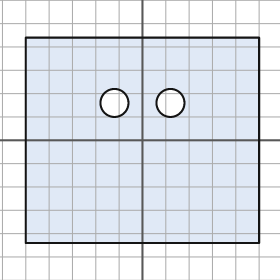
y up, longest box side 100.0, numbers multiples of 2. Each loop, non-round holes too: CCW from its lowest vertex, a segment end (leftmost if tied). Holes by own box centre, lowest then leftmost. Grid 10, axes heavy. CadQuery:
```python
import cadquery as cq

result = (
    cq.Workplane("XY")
    .moveTo(-50.0, -44.0)
    .lineTo(50.0, -44.0)
    .lineTo(50.0, 44.0)
    .lineTo(-50.0, 44.0)
    .close()
    .moveTo(-12.0, 16.0)
    .circle(6.0)
    .moveTo(12.0, 16.0)
    .circle(6.0)
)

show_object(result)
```